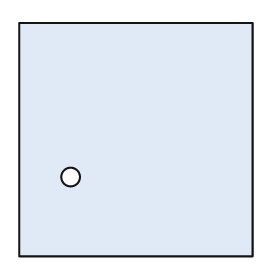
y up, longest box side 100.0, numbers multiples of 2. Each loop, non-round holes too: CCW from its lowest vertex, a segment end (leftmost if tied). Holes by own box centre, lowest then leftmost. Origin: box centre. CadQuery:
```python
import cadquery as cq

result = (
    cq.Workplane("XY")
    .moveTo(-50.0, -50.0)
    .lineTo(50.0, -50.0)
    .lineTo(50.0, 50.0)
    .lineTo(-50.0, 50.0)
    .close()
    .moveTo(-28.0, -16.0)
    .circle(4.0)
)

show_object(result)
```